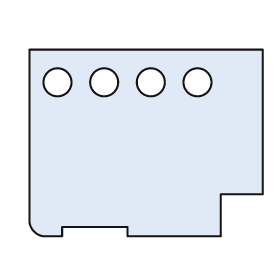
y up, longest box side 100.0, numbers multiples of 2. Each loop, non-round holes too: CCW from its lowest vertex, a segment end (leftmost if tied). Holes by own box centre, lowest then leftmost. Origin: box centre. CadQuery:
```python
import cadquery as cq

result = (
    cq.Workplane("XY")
    .moveTo(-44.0, -40.0)
    .lineTo(-36.0, -40.0)
    .lineTo(-36.0, -36.0)
    .lineTo(-8.0, -36.0)
    .lineTo(-8.0, -40.0)
    .lineTo(32.0, -40.0)
    .lineTo(32.0, -22.0)
    .lineTo(50.0, -22.0)
    .lineTo(50.0, 40.0)
    .lineTo(-50.0, 40.0)
    .lineTo(-50.0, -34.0)
    .threePointArc((-48.0, -38.0), (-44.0, -40.0))
    .close()
    .moveTo(-38.0, 26.0)
    .circle(6.0)
    .moveTo(-18.0, 26.0)
    .circle(6.0)
    .moveTo(2.0, 26.0)
    .circle(6.0)
    .moveTo(22.0, 26.0)
    .circle(6.0)
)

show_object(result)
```